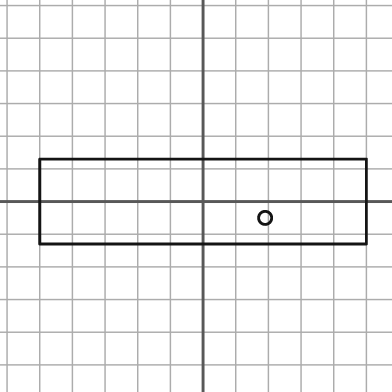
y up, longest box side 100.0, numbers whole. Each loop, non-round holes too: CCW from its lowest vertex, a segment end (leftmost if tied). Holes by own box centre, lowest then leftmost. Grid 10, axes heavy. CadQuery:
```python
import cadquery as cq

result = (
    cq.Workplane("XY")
    .moveTo(-50.0, -13.0)
    .lineTo(50.0, -13.0)
    .lineTo(50.0, 13.0)
    .lineTo(-50.0, 13.0)
    .close()
    .moveTo(19.0, -5.0)
    .circle(2.0)
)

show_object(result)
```